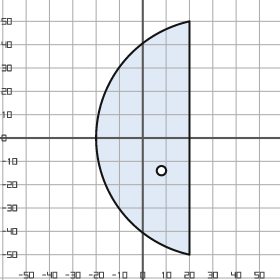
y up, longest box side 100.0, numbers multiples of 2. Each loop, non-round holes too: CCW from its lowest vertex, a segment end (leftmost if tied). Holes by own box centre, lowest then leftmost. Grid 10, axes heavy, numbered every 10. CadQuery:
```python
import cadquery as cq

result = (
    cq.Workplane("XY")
    .moveTo(20.0, -50.0)
    .lineTo(20.0, 50.0)
    .threePointArc((-20.0, 0.0), (20.0, -50.0))
    .close()
    .moveTo(8.0, -14.0)
    .circle(2.0)
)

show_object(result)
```